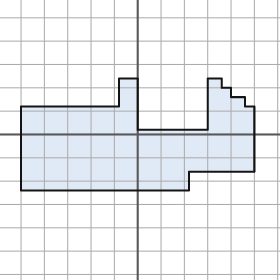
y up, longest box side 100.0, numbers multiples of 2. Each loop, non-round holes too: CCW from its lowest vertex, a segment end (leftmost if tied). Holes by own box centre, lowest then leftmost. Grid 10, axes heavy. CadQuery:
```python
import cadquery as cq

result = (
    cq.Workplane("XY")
    .moveTo(-50.0, -24.0)
    .lineTo(22.0, -24.0)
    .lineTo(22.0, -16.0)
    .lineTo(50.0, -16.0)
    .lineTo(50.0, 12.0)
    .lineTo(46.0, 12.0)
    .lineTo(46.0, 16.0)
    .lineTo(40.0, 16.0)
    .lineTo(40.0, 20.0)
    .lineTo(36.0, 20.0)
    .lineTo(36.0, 24.0)
    .lineTo(30.0, 24.0)
    .lineTo(30.0, 2.0)
    .lineTo(0.0, 2.0)
    .lineTo(0.0, 24.0)
    .lineTo(-8.0, 24.0)
    .lineTo(-8.0, 12.0)
    .lineTo(-50.0, 12.0)
    .close()
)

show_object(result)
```